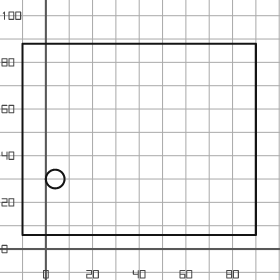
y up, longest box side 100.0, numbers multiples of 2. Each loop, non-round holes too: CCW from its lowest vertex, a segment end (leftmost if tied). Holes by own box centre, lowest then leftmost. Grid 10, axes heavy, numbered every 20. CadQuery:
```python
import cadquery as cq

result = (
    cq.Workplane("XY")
    .moveTo(-10.0, 6.0)
    .lineTo(90.0, 6.0)
    .lineTo(90.0, 88.0)
    .lineTo(-10.0, 88.0)
    .close()
    .moveTo(4.0, 30.0)
    .circle(4.0)
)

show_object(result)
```